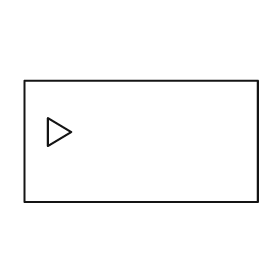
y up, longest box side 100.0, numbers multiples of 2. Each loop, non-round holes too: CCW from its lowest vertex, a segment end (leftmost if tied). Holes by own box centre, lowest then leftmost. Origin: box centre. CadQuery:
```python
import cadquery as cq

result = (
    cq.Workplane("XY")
    .moveTo(-50.0, -26.0)
    .lineTo(50.0, -26.0)
    .lineTo(50.0, 26.0)
    .lineTo(-50.0, 26.0)
    .close()
    .moveTo(-40.0, -2.0)
    .lineTo(-30.0, 4.0)
    .lineTo(-40.0, 10.0)
    .close()
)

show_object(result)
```